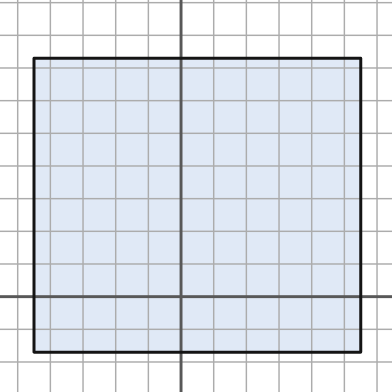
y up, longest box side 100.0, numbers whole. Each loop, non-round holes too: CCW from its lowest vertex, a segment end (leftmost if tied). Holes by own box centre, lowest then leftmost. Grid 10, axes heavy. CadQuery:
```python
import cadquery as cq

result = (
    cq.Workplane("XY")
    .moveTo(-45.0, -17.0)
    .lineTo(55.0, -17.0)
    .lineTo(55.0, 73.0)
    .lineTo(-45.0, 73.0)
    .close()
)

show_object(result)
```